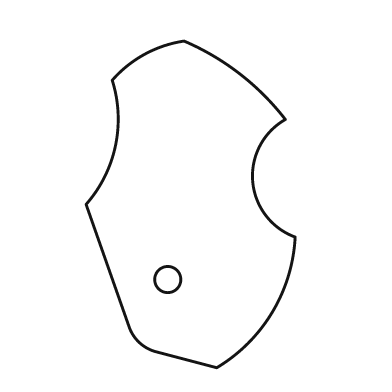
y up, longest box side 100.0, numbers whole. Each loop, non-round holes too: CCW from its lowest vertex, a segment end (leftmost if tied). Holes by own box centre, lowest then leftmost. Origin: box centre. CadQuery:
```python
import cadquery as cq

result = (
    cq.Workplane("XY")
    .moveTo(8.0, -50.0)
    .threePointArc((25.0, -33.0), (32.0, -10.0))
    .threePointArc((19.0, 7.0), (29.0, 26.0))
    .threePointArc((15.0, 40.0), (-2.0, 50.0))
    .threePointArc((-14.0, 46.0), (-24.0, 38.0))
    .threePointArc((-23.0, 18.0), (-32.0, 0.0))
    .lineTo(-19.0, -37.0)
    .threePointArc((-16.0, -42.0), (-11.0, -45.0))
    .close()
    .moveTo(-7.0, -23.0)
    .circle(4.0)
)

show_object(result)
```